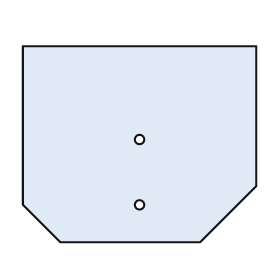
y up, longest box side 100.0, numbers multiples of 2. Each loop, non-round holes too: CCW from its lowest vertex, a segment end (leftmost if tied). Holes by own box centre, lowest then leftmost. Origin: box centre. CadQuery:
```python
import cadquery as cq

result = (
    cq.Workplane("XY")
    .moveTo(-34.0, -42.0)
    .lineTo(26.0, -42.0)
    .lineTo(50.0, -18.0)
    .lineTo(50.0, 42.0)
    .lineTo(-50.0, 42.0)
    .lineTo(-50.0, -26.0)
    .close()
    .moveTo(0.0, -26.0)
    .circle(2.0)
    .moveTo(0.0, 2.0)
    .circle(2.0)
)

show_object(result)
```